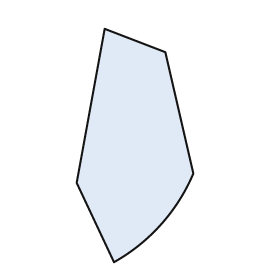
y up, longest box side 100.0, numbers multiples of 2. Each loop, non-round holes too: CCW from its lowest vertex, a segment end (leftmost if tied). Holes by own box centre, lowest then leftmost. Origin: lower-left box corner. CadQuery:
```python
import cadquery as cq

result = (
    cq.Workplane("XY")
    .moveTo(16.0, 0.0)
    .threePointArc((36.0, 16.0), (50.0, 38.0))
    .lineTo(38.0, 90.0)
    .lineTo(12.0, 100.0)
    .lineTo(0.0, 34.0)
    .close()
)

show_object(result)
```